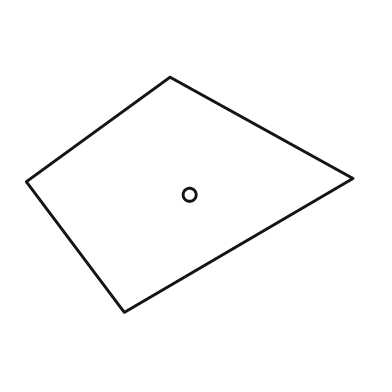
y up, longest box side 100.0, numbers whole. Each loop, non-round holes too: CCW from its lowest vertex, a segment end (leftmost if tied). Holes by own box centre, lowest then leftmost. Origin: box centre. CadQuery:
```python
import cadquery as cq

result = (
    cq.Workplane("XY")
    .moveTo(-20.0, -36.0)
    .lineTo(50.0, 5.0)
    .lineTo(-6.0, 36.0)
    .lineTo(-50.0, 4.0)
    .close()
    .moveTo(0.0, 0.0)
    .circle(2.0)
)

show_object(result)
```